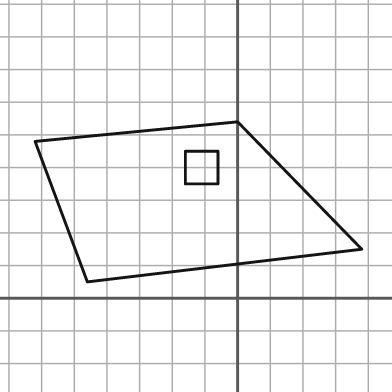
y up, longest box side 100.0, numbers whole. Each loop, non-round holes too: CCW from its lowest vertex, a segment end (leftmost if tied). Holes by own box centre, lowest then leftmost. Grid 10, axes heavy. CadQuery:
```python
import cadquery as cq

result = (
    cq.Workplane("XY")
    .moveTo(-46.0, 5.0)
    .lineTo(38.0, 15.0)
    .lineTo(0.0, 54.0)
    .lineTo(-62.0, 48.0)
    .close()
    .moveTo(-16.0, 35.0)
    .lineTo(-6.0, 35.0)
    .lineTo(-6.0, 45.0)
    .lineTo(-16.0, 45.0)
    .close()
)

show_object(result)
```